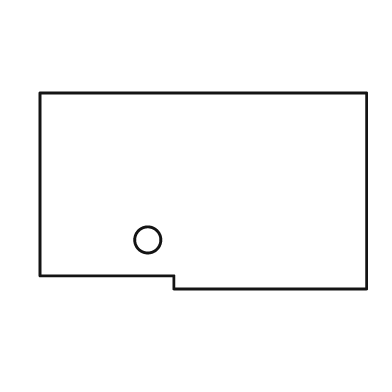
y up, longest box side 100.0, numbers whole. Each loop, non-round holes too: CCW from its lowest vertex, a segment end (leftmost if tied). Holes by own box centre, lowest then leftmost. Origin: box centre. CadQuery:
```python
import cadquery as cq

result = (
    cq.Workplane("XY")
    .moveTo(-9.0, -30.0)
    .lineTo(50.0, -30.0)
    .lineTo(50.0, 30.0)
    .lineTo(-50.0, 30.0)
    .lineTo(-50.0, -26.0)
    .lineTo(-9.0, -26.0)
    .close()
    .moveTo(-17.0, -15.0)
    .circle(4.0)
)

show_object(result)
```